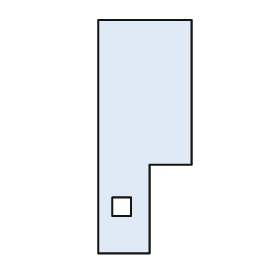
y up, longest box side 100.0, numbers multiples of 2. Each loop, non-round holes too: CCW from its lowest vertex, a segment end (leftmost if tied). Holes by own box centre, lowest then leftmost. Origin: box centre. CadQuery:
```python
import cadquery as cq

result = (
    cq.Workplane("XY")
    .moveTo(-20.0, -50.0)
    .lineTo(2.0, -50.0)
    .lineTo(2.0, -12.0)
    .lineTo(20.0, -12.0)
    .lineTo(20.0, 50.0)
    .lineTo(-20.0, 50.0)
    .close()
    .moveTo(-14.0, -34.0)
    .lineTo(-6.0, -34.0)
    .lineTo(-6.0, -26.0)
    .lineTo(-14.0, -26.0)
    .close()
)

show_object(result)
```